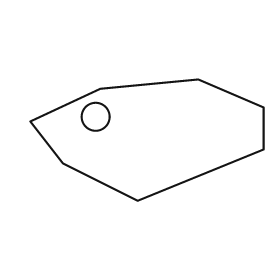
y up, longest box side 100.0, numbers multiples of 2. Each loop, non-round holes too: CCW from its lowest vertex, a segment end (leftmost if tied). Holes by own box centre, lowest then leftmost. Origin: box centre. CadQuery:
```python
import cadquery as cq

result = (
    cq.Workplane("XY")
    .moveTo(-4.0, -26.0)
    .lineTo(50.0, -4.0)
    .lineTo(50.0, 14.0)
    .lineTo(22.0, 26.0)
    .lineTo(-20.0, 22.0)
    .lineTo(-50.0, 8.0)
    .lineTo(-36.0, -10.0)
    .close()
    .moveTo(-22.0, 10.0)
    .circle(6.0)
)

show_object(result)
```